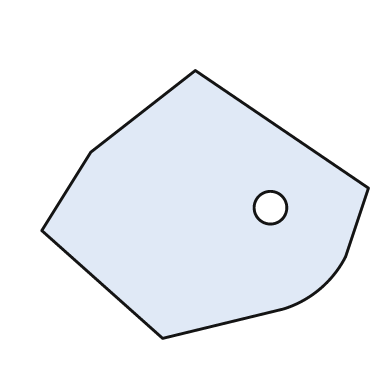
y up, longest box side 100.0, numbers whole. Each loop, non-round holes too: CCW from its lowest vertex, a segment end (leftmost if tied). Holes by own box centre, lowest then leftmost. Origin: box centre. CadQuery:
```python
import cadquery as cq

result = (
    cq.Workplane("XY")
    .moveTo(-13.0, -41.0)
    .lineTo(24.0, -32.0)
    .threePointArc((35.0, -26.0), (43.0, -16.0))
    .lineTo(50.0, 5.0)
    .lineTo(-3.0, 41.0)
    .lineTo(-35.0, 16.0)
    .lineTo(-50.0, -8.0)
    .close()
    .moveTo(20.0, -1.0)
    .circle(5.0)
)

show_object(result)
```